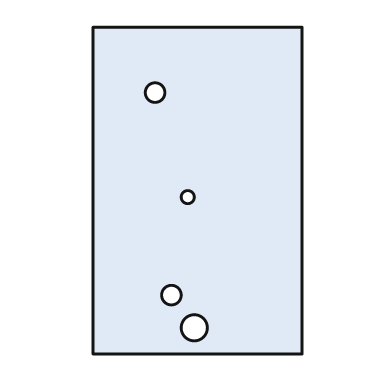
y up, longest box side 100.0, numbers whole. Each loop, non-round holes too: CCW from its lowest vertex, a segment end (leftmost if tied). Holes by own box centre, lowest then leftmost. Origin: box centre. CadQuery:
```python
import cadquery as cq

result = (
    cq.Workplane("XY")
    .moveTo(-32.0, -50.0)
    .lineTo(32.0, -50.0)
    .lineTo(32.0, 50.0)
    .lineTo(-32.0, 50.0)
    .close()
    .moveTo(-1.0, -42.0)
    .circle(4.0)
    .moveTo(-8.0, -32.0)
    .circle(3.0)
    .moveTo(-3.0, -2.0)
    .circle(2.0)
    .moveTo(-13.0, 30.0)
    .circle(3.0)
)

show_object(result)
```